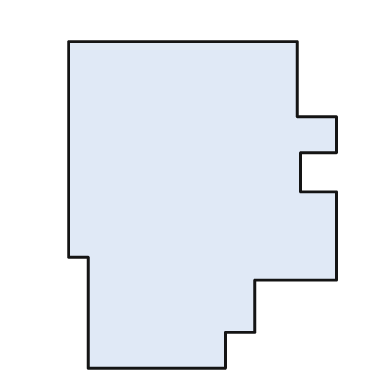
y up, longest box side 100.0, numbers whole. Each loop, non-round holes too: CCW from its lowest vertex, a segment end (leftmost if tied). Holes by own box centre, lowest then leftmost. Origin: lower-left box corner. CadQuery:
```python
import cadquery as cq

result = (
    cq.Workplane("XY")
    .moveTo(6.0, 0.0)
    .lineTo(48.0, 0.0)
    .lineTo(48.0, 11.0)
    .lineTo(57.0, 11.0)
    .lineTo(57.0, 27.0)
    .lineTo(82.0, 27.0)
    .lineTo(82.0, 54.0)
    .lineTo(71.0, 54.0)
    .lineTo(71.0, 66.0)
    .lineTo(82.0, 66.0)
    .lineTo(82.0, 77.0)
    .lineTo(70.0, 77.0)
    .lineTo(70.0, 100.0)
    .lineTo(0.0, 100.0)
    .lineTo(0.0, 34.0)
    .lineTo(6.0, 34.0)
    .close()
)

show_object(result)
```